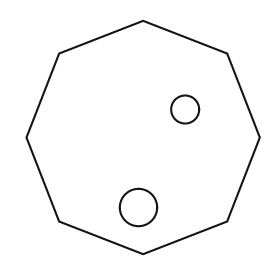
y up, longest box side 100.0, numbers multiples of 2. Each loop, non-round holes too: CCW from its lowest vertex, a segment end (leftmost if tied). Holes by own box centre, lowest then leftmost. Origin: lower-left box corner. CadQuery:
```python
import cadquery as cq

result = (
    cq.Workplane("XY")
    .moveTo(50.0, 0.0)
    .lineTo(86.0, 14.0)
    .lineTo(100.0, 50.0)
    .lineTo(86.0, 86.0)
    .lineTo(50.0, 100.0)
    .lineTo(14.0, 86.0)
    .lineTo(0.0, 50.0)
    .lineTo(14.0, 14.0)
    .close()
    .moveTo(48.0, 20.0)
    .circle(8.0)
    .moveTo(68.0, 62.0)
    .circle(6.0)
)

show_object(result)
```